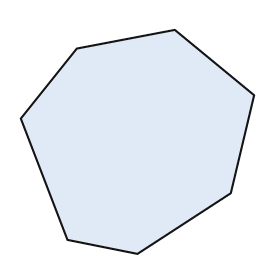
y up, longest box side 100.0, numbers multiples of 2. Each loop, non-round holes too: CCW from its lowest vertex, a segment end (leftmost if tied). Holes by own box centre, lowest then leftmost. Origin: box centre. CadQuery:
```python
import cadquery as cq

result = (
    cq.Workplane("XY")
    .moveTo(0.0, -48.0)
    .lineTo(40.0, -22.0)
    .lineTo(50.0, 20.0)
    .lineTo(16.0, 48.0)
    .lineTo(-26.0, 40.0)
    .lineTo(-50.0, 10.0)
    .lineTo(-30.0, -42.0)
    .close()
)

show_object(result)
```